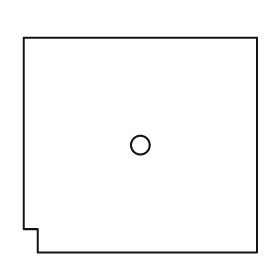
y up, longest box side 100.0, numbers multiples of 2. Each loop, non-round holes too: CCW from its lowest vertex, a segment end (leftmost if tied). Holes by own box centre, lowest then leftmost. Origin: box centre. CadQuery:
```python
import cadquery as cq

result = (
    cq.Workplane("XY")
    .moveTo(-44.0, -46.0)
    .lineTo(50.0, -46.0)
    .lineTo(50.0, 46.0)
    .lineTo(-50.0, 46.0)
    .lineTo(-50.0, -36.0)
    .lineTo(-44.0, -36.0)
    .close()
    .moveTo(0.0, 0.0)
    .circle(4.0)
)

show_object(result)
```